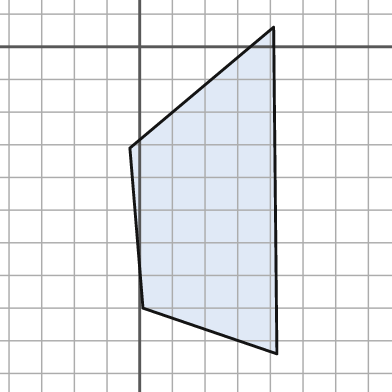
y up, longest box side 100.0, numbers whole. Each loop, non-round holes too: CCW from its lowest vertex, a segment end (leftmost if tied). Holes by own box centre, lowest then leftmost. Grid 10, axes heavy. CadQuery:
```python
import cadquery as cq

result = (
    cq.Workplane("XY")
    .moveTo(42.0, -94.0)
    .lineTo(41.0, 6.0)
    .lineTo(-3.0, -31.0)
    .lineTo(1.0, -80.0)
    .close()
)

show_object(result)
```